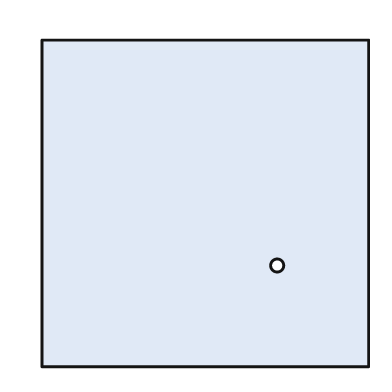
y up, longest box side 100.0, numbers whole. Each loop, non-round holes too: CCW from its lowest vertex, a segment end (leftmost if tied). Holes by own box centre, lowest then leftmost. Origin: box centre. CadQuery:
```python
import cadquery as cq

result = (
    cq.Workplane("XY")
    .moveTo(-50.0, -50.0)
    .lineTo(50.0, -50.0)
    .lineTo(50.0, 50.0)
    .lineTo(-50.0, 50.0)
    .close()
    .moveTo(22.0, -19.0)
    .circle(2.0)
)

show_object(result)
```